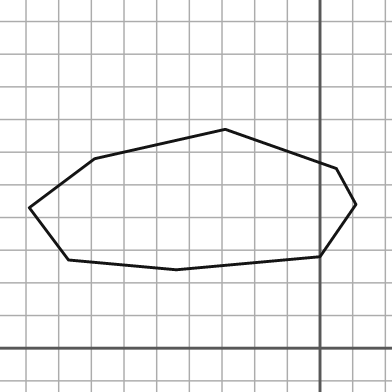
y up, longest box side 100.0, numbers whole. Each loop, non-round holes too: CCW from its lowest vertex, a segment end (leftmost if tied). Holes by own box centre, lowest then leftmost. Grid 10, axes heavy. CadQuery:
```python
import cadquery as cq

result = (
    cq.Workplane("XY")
    .moveTo(-44.0, 24.0)
    .lineTo(0.0, 28.0)
    .lineTo(11.0, 44.0)
    .lineTo(5.0, 55.0)
    .lineTo(-29.0, 67.0)
    .lineTo(-69.0, 58.0)
    .lineTo(-89.0, 43.0)
    .lineTo(-77.0, 27.0)
    .close()
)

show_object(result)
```